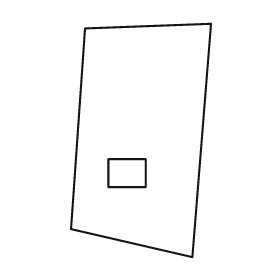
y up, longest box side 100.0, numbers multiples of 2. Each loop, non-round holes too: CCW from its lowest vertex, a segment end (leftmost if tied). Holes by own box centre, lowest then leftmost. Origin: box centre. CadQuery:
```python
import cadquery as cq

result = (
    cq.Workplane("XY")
    .moveTo(22.0, -50.0)
    .lineTo(30.0, 50.0)
    .lineTo(-24.0, 48.0)
    .lineTo(-30.0, -38.0)
    .close()
    .moveTo(-14.0, -20.0)
    .lineTo(2.0, -20.0)
    .lineTo(2.0, -8.0)
    .lineTo(-14.0, -8.0)
    .close()
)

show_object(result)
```